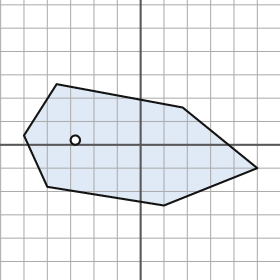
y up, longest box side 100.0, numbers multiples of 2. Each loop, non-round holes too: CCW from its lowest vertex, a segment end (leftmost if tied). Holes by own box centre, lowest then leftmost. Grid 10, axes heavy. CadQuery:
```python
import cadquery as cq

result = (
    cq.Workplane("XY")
    .moveTo(10.0, -26.0)
    .lineTo(50.0, -10.0)
    .lineTo(18.0, 16.0)
    .lineTo(-36.0, 26.0)
    .lineTo(-50.0, 4.0)
    .lineTo(-40.0, -18.0)
    .close()
    .moveTo(-28.0, 2.0)
    .circle(2.0)
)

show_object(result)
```